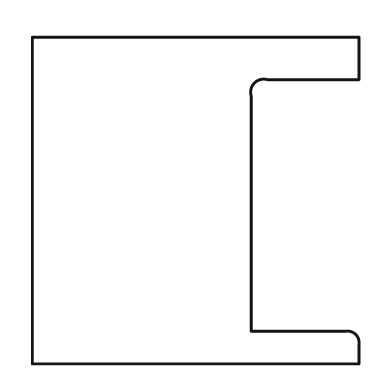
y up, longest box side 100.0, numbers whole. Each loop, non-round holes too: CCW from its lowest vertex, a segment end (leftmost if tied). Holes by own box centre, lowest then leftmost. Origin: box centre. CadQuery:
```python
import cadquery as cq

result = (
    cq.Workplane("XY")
    .moveTo(-50.0, -50.0)
    .lineTo(50.0, -50.0)
    .lineTo(50.0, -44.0)
    .threePointArc((49.0, -41.0), (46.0, -40.0))
    .lineTo(17.0, -40.0)
    .lineTo(17.0, 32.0)
    .threePointArc((18.0, 36.0), (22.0, 37.0))
    .lineTo(50.0, 37.0)
    .lineTo(50.0, 50.0)
    .lineTo(-50.0, 50.0)
    .close()
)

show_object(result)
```